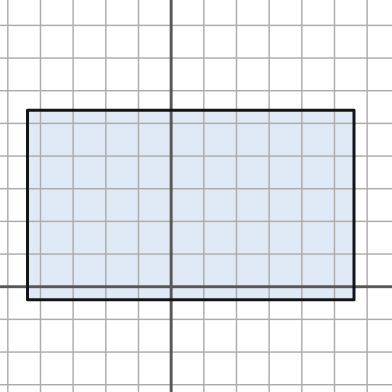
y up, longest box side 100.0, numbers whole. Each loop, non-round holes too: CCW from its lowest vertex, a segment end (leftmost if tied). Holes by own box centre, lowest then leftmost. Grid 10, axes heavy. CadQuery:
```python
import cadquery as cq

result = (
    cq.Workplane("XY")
    .moveTo(-44.0, -4.0)
    .lineTo(56.0, -4.0)
    .lineTo(56.0, 54.0)
    .lineTo(-44.0, 54.0)
    .close()
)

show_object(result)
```